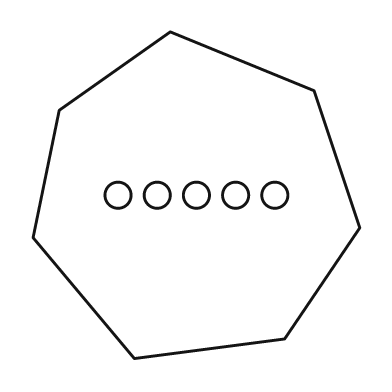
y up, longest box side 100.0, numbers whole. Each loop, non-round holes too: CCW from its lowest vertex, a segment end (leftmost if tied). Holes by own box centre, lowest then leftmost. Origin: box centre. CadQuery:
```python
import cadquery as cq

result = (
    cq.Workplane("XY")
    .moveTo(-19.0, -50.0)
    .lineTo(27.0, -44.0)
    .lineTo(50.0, -10.0)
    .lineTo(36.0, 32.0)
    .lineTo(-8.0, 50.0)
    .lineTo(-42.0, 26.0)
    .lineTo(-50.0, -13.0)
    .close()
    .moveTo(-24.0, 0.0)
    .circle(4.0)
    .moveTo(-12.0, 0.0)
    .circle(4.0)
    .moveTo(0.0, 0.0)
    .circle(4.0)
    .moveTo(12.0, 0.0)
    .circle(4.0)
    .moveTo(24.0, 0.0)
    .circle(4.0)
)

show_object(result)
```